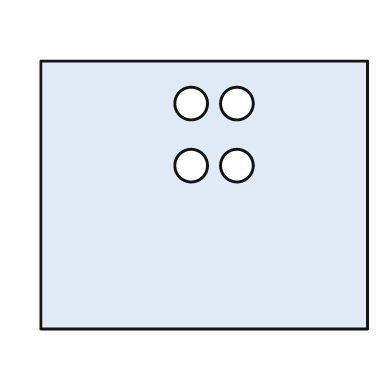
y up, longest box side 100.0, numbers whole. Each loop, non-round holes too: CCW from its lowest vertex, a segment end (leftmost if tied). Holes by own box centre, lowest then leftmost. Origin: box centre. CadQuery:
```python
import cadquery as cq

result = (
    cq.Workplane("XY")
    .moveTo(-50.0, -41.0)
    .lineTo(50.0, -41.0)
    .lineTo(50.0, 41.0)
    .lineTo(-50.0, 41.0)
    .close()
    .moveTo(-4.0, 9.0)
    .circle(5.0)
    .moveTo(10.0, 9.0)
    .circle(5.0)
    .moveTo(-4.0, 28.0)
    .circle(5.0)
    .moveTo(10.0, 28.0)
    .circle(5.0)
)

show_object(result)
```